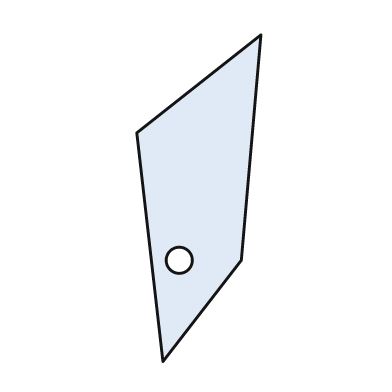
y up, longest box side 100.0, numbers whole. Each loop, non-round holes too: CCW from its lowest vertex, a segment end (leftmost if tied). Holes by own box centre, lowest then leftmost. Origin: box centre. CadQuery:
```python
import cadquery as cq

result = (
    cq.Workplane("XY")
    .moveTo(-11.0, -50.0)
    .lineTo(13.0, -19.0)
    .lineTo(19.0, 50.0)
    .lineTo(-19.0, 20.0)
    .close()
    .moveTo(-6.0, -19.0)
    .circle(4.0)
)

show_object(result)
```